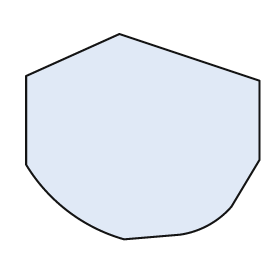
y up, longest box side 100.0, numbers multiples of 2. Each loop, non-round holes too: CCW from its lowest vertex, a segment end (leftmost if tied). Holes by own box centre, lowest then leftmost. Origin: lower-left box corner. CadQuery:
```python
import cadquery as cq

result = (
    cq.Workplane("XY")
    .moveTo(42.0, 0.0)
    .lineTo(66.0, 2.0)
    .threePointArc((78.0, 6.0), (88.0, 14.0))
    .lineTo(100.0, 34.0)
    .lineTo(100.0, 68.0)
    .lineTo(40.0, 88.0)
    .lineTo(0.0, 70.0)
    .lineTo(0.0, 32.0)
    .threePointArc((18.0, 12.0), (42.0, 0.0))
    .close()
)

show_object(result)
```